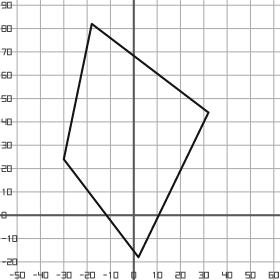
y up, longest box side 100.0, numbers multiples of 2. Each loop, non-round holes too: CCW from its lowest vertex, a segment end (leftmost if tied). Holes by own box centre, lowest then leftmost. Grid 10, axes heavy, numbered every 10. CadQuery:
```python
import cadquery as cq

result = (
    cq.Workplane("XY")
    .moveTo(2.0, -18.0)
    .lineTo(32.0, 44.0)
    .lineTo(-18.0, 82.0)
    .lineTo(-30.0, 24.0)
    .close()
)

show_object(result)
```